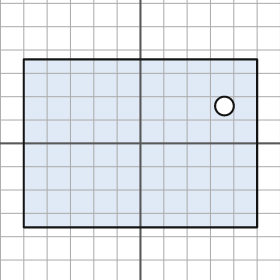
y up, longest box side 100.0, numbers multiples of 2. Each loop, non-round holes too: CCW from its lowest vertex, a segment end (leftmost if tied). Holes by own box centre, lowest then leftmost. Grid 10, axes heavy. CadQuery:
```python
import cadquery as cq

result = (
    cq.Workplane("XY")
    .moveTo(-50.0, -36.0)
    .lineTo(50.0, -36.0)
    .lineTo(50.0, 36.0)
    .lineTo(-50.0, 36.0)
    .close()
    .moveTo(36.0, 16.0)
    .circle(4.0)
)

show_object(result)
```